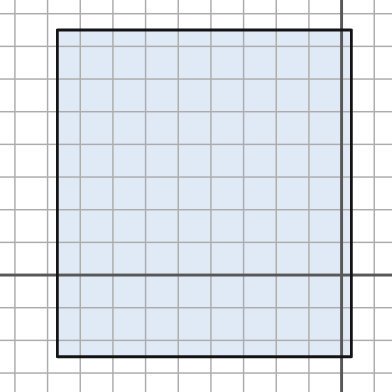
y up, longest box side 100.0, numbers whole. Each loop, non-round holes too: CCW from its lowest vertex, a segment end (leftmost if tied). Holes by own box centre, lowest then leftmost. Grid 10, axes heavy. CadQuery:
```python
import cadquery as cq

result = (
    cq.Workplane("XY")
    .moveTo(-87.0, -25.0)
    .lineTo(3.0, -25.0)
    .lineTo(3.0, 75.0)
    .lineTo(-87.0, 75.0)
    .close()
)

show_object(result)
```